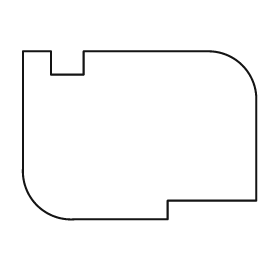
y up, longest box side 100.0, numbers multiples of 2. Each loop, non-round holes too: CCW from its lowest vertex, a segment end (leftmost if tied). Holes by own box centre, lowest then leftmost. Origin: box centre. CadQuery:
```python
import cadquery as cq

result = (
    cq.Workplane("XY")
    .moveTo(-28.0, -36.0)
    .lineTo(12.0, -36.0)
    .lineTo(12.0, -28.0)
    .lineTo(50.0, -28.0)
    .lineTo(50.0, 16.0)
    .threePointArc((44.0, 30.0), (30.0, 36.0))
    .lineTo(-24.0, 36.0)
    .lineTo(-24.0, 26.0)
    .lineTo(-38.0, 26.0)
    .lineTo(-38.0, 36.0)
    .lineTo(-50.0, 36.0)
    .lineTo(-50.0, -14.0)
    .threePointArc((-44.0, -30.0), (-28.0, -36.0))
    .close()
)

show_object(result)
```